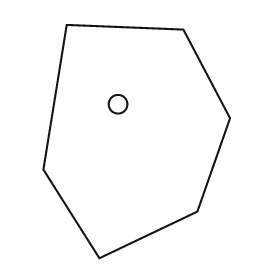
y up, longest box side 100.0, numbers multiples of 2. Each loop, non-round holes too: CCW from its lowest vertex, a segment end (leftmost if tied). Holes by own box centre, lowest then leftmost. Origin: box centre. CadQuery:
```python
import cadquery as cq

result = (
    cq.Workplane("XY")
    .moveTo(-16.0, -50.0)
    .lineTo(26.0, -30.0)
    .lineTo(40.0, 10.0)
    .lineTo(20.0, 48.0)
    .lineTo(-30.0, 50.0)
    .lineTo(-40.0, -12.0)
    .close()
    .moveTo(-8.0, 16.0)
    .circle(4.0)
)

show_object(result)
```